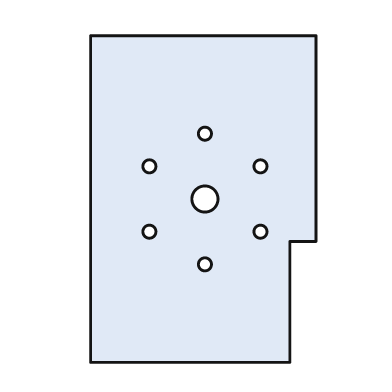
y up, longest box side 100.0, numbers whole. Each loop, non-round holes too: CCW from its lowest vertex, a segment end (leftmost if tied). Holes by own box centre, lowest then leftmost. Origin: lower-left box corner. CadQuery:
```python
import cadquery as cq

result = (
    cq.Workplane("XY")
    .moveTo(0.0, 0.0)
    .lineTo(61.0, 0.0)
    .lineTo(61.0, 37.0)
    .lineTo(69.0, 37.0)
    .lineTo(69.0, 100.0)
    .lineTo(0.0, 100.0)
    .close()
    .moveTo(35.0, 30.0)
    .circle(2.0)
    .moveTo(18.0, 40.0)
    .circle(2.0)
    .moveTo(52.0, 40.0)
    .circle(2.0)
    .moveTo(35.0, 50.0)
    .circle(4.0)
    .moveTo(18.0, 60.0)
    .circle(2.0)
    .moveTo(52.0, 60.0)
    .circle(2.0)
    .moveTo(35.0, 70.0)
    .circle(2.0)
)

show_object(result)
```